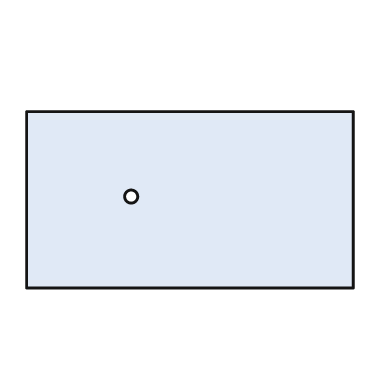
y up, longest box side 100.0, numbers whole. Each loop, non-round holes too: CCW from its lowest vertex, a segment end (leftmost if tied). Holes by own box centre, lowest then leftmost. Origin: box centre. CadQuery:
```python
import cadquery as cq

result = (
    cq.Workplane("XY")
    .moveTo(-50.0, -27.0)
    .lineTo(50.0, -27.0)
    .lineTo(50.0, 27.0)
    .lineTo(-50.0, 27.0)
    .close()
    .moveTo(-18.0, 1.0)
    .circle(2.0)
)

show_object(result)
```